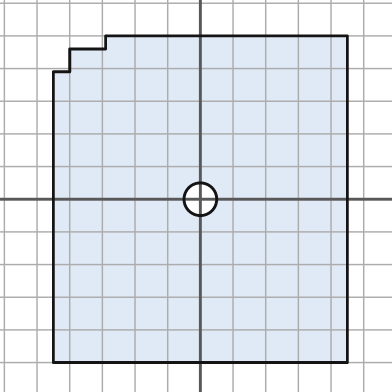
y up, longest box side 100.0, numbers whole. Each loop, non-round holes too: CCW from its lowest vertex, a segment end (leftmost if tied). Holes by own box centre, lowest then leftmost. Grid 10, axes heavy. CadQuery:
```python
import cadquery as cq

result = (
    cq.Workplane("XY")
    .moveTo(-45.0, -50.0)
    .lineTo(45.0, -50.0)
    .lineTo(45.0, 50.0)
    .lineTo(-29.0, 50.0)
    .lineTo(-29.0, 46.0)
    .lineTo(-40.0, 46.0)
    .lineTo(-40.0, 39.0)
    .lineTo(-45.0, 39.0)
    .close()
    .moveTo(0.0, 0.0)
    .circle(5.0)
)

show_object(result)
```